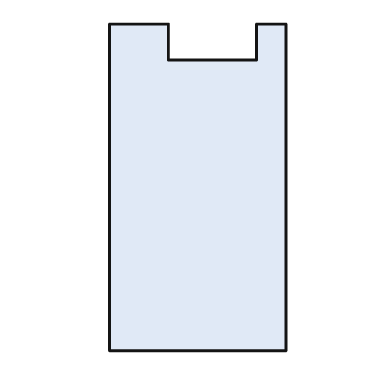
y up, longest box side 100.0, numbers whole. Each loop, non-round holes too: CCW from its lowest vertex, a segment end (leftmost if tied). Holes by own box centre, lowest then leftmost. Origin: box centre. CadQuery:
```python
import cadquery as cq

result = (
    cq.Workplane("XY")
    .moveTo(-27.0, -50.0)
    .lineTo(27.0, -50.0)
    .lineTo(27.0, 50.0)
    .lineTo(18.0, 50.0)
    .lineTo(18.0, 39.0)
    .lineTo(-9.0, 39.0)
    .lineTo(-9.0, 50.0)
    .lineTo(-27.0, 50.0)
    .close()
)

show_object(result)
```